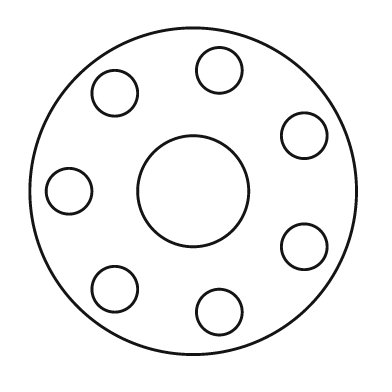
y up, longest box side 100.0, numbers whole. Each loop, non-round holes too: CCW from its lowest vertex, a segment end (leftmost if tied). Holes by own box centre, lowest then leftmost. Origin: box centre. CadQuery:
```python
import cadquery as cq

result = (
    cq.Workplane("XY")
    .moveTo(0.0, 0.0)
    .circle(50.0)
    .moveTo(8.0, -37.0)
    .circle(7.0)
    .moveTo(-24.0, -30.0)
    .circle(7.0)
    .moveTo(34.0, -17.0)
    .circle(7.0)
    .moveTo(-38.0, 0.0)
    .circle(7.0)
    .moveTo(0.0, 0.0)
    .circle(17.0)
    .moveTo(34.0, 17.0)
    .circle(7.0)
    .moveTo(-24.0, 30.0)
    .circle(7.0)
    .moveTo(8.0, 37.0)
    .circle(7.0)
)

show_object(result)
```